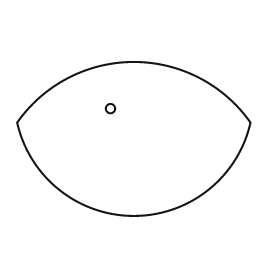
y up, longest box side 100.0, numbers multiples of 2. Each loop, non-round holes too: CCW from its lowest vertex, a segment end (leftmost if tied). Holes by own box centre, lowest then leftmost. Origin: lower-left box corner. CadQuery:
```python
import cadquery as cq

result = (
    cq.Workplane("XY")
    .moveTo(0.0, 40.0)
    .threePointArc((50.0, 0.0), (100.0, 40.0))
    .threePointArc((50.0, 66.0), (0.0, 40.0))
    .close()
    .moveTo(40.0, 46.0)
    .circle(2.0)
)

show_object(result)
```